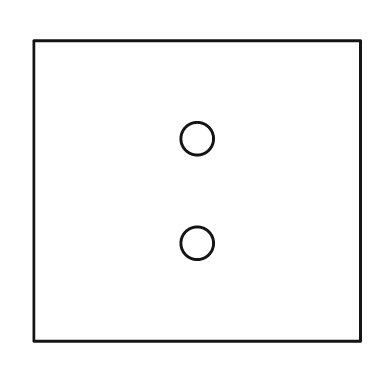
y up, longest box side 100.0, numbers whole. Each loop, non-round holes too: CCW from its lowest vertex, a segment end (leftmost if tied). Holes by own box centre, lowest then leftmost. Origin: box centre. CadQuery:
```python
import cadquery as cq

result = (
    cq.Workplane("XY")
    .moveTo(-50.0, -46.0)
    .lineTo(50.0, -46.0)
    .lineTo(50.0, 46.0)
    .lineTo(-50.0, 46.0)
    .close()
    .moveTo(0.0, -16.0)
    .circle(5.0)
    .moveTo(0.0, 16.0)
    .circle(5.0)
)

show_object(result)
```